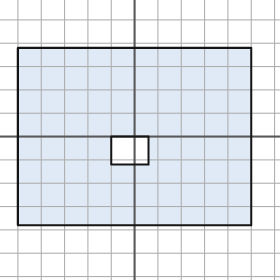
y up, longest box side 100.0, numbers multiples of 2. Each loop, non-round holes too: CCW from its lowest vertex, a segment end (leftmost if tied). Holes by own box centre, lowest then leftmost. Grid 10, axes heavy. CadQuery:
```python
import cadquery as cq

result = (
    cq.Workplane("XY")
    .moveTo(-50.0, -38.0)
    .lineTo(50.0, -38.0)
    .lineTo(50.0, 38.0)
    .lineTo(-50.0, 38.0)
    .close()
    .moveTo(-10.0, -12.0)
    .lineTo(6.0, -12.0)
    .lineTo(6.0, 0.0)
    .lineTo(-10.0, 0.0)
    .close()
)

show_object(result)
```